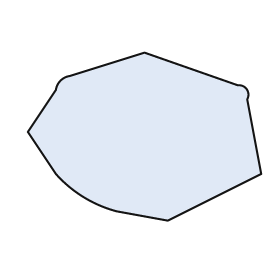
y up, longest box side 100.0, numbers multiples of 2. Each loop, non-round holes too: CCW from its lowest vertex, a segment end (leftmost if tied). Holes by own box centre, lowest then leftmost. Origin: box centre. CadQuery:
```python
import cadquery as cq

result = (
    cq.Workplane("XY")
    .moveTo(10.0, -36.0)
    .lineTo(50.0, -16.0)
    .lineTo(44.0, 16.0)
    .threePointArc((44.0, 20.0), (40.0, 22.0))
    .lineTo(0.0, 36.0)
    .lineTo(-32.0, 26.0)
    .threePointArc((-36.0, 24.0), (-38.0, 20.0))
    .lineTo(-50.0, 2.0)
    .lineTo(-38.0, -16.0)
    .threePointArc((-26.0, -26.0), (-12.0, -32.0))
    .close()
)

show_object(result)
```